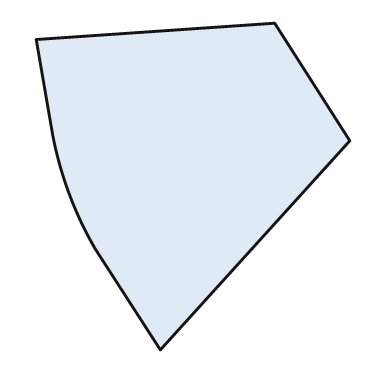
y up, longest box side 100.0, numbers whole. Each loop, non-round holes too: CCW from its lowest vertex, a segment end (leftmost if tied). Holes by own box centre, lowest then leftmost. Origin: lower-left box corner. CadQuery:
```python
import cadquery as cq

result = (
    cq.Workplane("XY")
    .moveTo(38.0, 0.0)
    .lineTo(96.0, 64.0)
    .lineTo(73.0, 100.0)
    .lineTo(0.0, 95.0)
    .lineTo(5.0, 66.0)
    .threePointArc((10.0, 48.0), (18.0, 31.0))
    .close()
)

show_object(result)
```